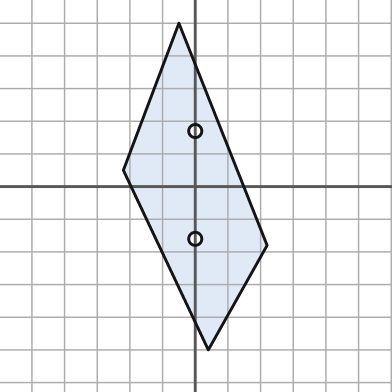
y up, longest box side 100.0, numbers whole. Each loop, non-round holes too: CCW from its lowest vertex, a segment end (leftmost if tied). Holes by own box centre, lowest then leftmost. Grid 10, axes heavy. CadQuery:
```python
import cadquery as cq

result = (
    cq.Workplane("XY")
    .moveTo(4.0, -50.0)
    .lineTo(22.0, -18.0)
    .lineTo(-5.0, 50.0)
    .lineTo(-22.0, 5.0)
    .close()
    .moveTo(0.0, -16.0)
    .circle(2.0)
    .moveTo(0.0, 17.0)
    .circle(2.0)
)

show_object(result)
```